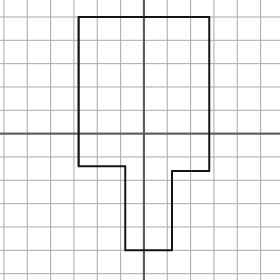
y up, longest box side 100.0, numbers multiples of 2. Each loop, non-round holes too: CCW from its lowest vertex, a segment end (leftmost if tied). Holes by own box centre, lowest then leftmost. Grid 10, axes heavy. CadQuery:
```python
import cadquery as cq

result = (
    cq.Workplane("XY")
    .moveTo(-8.0, -50.0)
    .lineTo(12.0, -50.0)
    .lineTo(12.0, -16.0)
    .lineTo(28.0, -16.0)
    .lineTo(28.0, 50.0)
    .lineTo(-28.0, 50.0)
    .lineTo(-28.0, -14.0)
    .lineTo(-8.0, -14.0)
    .close()
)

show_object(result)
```